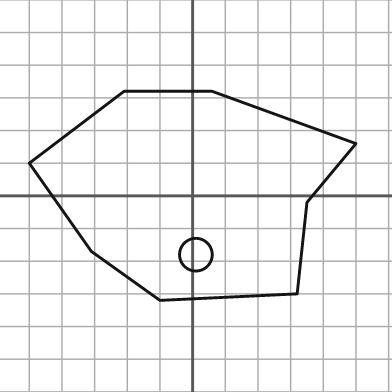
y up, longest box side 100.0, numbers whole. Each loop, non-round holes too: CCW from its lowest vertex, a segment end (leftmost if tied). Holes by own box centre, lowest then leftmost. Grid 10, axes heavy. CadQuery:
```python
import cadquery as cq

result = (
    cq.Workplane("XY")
    .moveTo(-10.0, -32.0)
    .lineTo(32.0, -30.0)
    .lineTo(35.0, -2.0)
    .lineTo(50.0, 16.0)
    .lineTo(6.0, 32.0)
    .lineTo(-21.0, 32.0)
    .lineTo(-50.0, 10.0)
    .lineTo(-31.0, -17.0)
    .close()
    .moveTo(1.0, -18.0)
    .circle(5.0)
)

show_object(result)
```